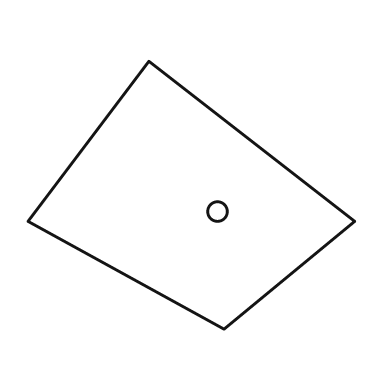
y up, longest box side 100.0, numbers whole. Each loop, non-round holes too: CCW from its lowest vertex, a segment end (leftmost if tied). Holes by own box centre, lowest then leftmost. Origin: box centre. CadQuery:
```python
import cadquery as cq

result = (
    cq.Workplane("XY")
    .moveTo(10.0, -41.0)
    .lineTo(50.0, -8.0)
    .lineTo(-13.0, 41.0)
    .lineTo(-50.0, -8.0)
    .close()
    .moveTo(8.0, -5.0)
    .circle(3.0)
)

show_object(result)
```